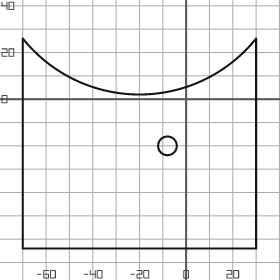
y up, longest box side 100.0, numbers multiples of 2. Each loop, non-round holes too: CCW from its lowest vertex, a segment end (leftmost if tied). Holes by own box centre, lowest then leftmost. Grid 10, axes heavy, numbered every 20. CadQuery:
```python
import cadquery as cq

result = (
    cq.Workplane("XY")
    .moveTo(-70.0, -64.0)
    .lineTo(30.0, -64.0)
    .lineTo(30.0, 26.0)
    .threePointArc((-20.0, 2.0), (-70.0, 26.0))
    .close()
    .moveTo(-8.0, -20.0)
    .circle(4.0)
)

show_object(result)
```